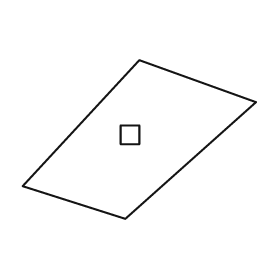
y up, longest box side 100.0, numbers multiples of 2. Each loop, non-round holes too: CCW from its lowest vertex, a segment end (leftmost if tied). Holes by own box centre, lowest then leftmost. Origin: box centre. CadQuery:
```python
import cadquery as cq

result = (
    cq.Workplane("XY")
    .moveTo(-6.0, -34.0)
    .lineTo(50.0, 16.0)
    .lineTo(0.0, 34.0)
    .lineTo(-50.0, -20.0)
    .close()
    .moveTo(-8.0, -2.0)
    .lineTo(0.0, -2.0)
    .lineTo(0.0, 6.0)
    .lineTo(-8.0, 6.0)
    .close()
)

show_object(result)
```